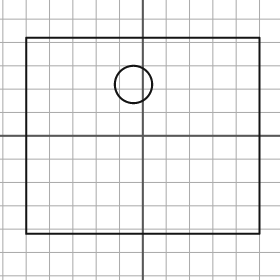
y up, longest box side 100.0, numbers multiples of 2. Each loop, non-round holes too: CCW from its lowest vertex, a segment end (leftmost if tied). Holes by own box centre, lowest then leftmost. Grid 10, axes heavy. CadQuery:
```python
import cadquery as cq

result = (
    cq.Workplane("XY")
    .moveTo(-50.0, -42.0)
    .lineTo(50.0, -42.0)
    .lineTo(50.0, 42.0)
    .lineTo(-50.0, 42.0)
    .close()
    .moveTo(-4.0, 22.0)
    .circle(8.0)
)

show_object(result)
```